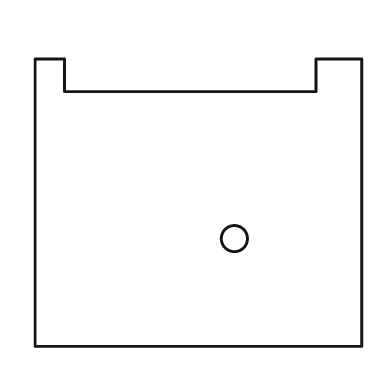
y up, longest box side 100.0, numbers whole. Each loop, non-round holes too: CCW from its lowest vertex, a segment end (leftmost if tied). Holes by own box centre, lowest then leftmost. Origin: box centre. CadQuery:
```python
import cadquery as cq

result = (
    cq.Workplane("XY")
    .moveTo(-50.0, -44.0)
    .lineTo(50.0, -44.0)
    .lineTo(50.0, 44.0)
    .lineTo(36.0, 44.0)
    .lineTo(36.0, 34.0)
    .lineTo(-41.0, 34.0)
    .lineTo(-41.0, 44.0)
    .lineTo(-50.0, 44.0)
    .close()
    .moveTo(11.0, -11.0)
    .circle(4.0)
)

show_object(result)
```